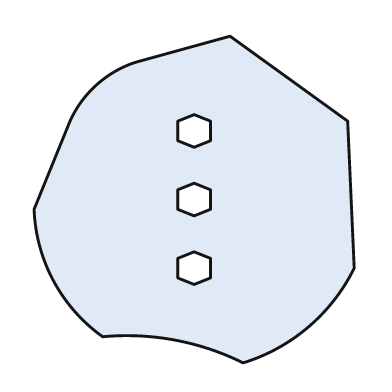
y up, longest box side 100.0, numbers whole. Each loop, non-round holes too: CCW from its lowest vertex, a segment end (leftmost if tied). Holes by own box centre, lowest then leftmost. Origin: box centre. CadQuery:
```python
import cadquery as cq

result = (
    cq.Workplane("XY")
    .moveTo(15.0, -50.0)
    .threePointArc((35.0, -39.0), (49.0, -21.0))
    .lineTo(47.0, 24.0)
    .lineTo(11.0, 50.0)
    .lineTo(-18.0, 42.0)
    .threePointArc((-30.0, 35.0), (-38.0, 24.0))
    .lineTo(-49.0, -3.0)
    .threePointArc((-43.0, -25.0), (-28.0, -42.0))
    .threePointArc((-6.0, -43.0), (15.0, -50.0))
    .close()
    .moveTo(0.0, -26.0)
    .lineTo(5.0, -24.0)
    .lineTo(5.0, -18.0)
    .lineTo(0.0, -16.0)
    .lineTo(-5.0, -18.0)
    .lineTo(-5.0, -24.0)
    .close()
    .moveTo(0.0, -5.0)
    .lineTo(5.0, -3.0)
    .lineTo(5.0, 3.0)
    .lineTo(0.0, 5.0)
    .lineTo(-5.0, 3.0)
    .lineTo(-5.0, -3.0)
    .close()
    .moveTo(0.0, 16.0)
    .lineTo(5.0, 18.0)
    .lineTo(5.0, 24.0)
    .lineTo(0.0, 26.0)
    .lineTo(-5.0, 24.0)
    .lineTo(-5.0, 18.0)
    .close()
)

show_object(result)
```